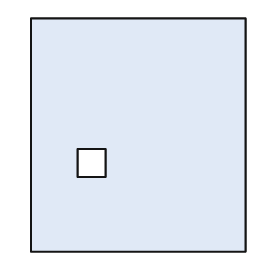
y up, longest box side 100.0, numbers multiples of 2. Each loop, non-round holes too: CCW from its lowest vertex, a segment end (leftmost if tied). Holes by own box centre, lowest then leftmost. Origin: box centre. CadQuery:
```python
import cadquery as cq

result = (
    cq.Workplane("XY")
    .moveTo(-46.0, -50.0)
    .lineTo(46.0, -50.0)
    .lineTo(46.0, 50.0)
    .lineTo(-46.0, 50.0)
    .close()
    .moveTo(-26.0, -18.0)
    .lineTo(-14.0, -18.0)
    .lineTo(-14.0, -6.0)
    .lineTo(-26.0, -6.0)
    .close()
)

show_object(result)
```